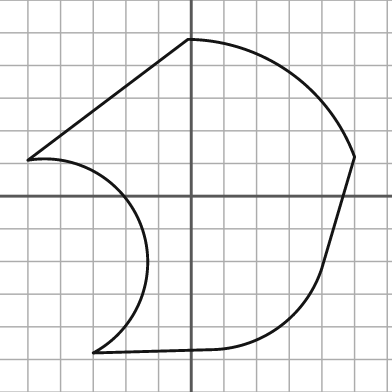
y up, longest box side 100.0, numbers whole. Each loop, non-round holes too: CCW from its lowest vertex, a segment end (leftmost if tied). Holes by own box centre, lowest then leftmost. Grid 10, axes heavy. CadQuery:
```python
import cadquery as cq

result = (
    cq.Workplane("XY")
    .moveTo(-30.0, -48.0)
    .lineTo(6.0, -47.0)
    .threePointArc((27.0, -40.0), (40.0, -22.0))
    .lineTo(50.0, 12.0)
    .threePointArc((30.0, 38.0), (-1.0, 48.0))
    .lineTo(-50.0, 11.0)
    .threePointArc((-15.0, -10.0), (-30.0, -48.0))
    .close()
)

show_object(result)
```